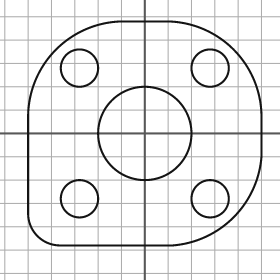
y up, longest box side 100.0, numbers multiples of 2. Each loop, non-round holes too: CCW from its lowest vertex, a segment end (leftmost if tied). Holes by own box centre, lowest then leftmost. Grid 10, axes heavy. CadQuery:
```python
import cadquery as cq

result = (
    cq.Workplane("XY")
    .moveTo(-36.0, -48.0)
    .lineTo(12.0, -48.0)
    .threePointArc((38.0, -36.0), (50.0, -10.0))
    .lineTo(50.0, 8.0)
    .threePointArc((38.0, 36.0), (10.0, 48.0))
    .lineTo(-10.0, 48.0)
    .threePointArc((-38.0, 36.0), (-50.0, 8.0))
    .lineTo(-50.0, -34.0)
    .threePointArc((-46.0, -44.0), (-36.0, -48.0))
    .close()
    .moveTo(-28.0, -28.0)
    .circle(8.0)
    .moveTo(28.0, -28.0)
    .circle(8.0)
    .moveTo(0.0, 0.0)
    .circle(20.0)
    .moveTo(-28.0, 28.0)
    .circle(8.0)
    .moveTo(28.0, 28.0)
    .circle(8.0)
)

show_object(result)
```